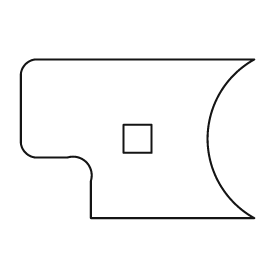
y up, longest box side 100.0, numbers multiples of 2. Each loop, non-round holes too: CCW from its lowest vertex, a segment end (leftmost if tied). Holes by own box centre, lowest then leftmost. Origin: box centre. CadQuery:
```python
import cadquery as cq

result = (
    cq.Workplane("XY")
    .moveTo(-20.0, -34.0)
    .lineTo(50.0, -34.0)
    .threePointArc((30.0, 0.0), (50.0, 34.0))
    .lineTo(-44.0, 34.0)
    .threePointArc((-48.0, 32.0), (-50.0, 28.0))
    .lineTo(-50.0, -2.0)
    .threePointArc((-48.0, -6.0), (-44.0, -8.0))
    .lineTo(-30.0, -8.0)
    .threePointArc((-22.0, -10.0), (-20.0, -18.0))
    .close()
    .moveTo(-6.0, -6.0)
    .lineTo(6.0, -6.0)
    .lineTo(6.0, 6.0)
    .lineTo(-6.0, 6.0)
    .close()
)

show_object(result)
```